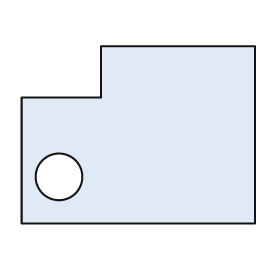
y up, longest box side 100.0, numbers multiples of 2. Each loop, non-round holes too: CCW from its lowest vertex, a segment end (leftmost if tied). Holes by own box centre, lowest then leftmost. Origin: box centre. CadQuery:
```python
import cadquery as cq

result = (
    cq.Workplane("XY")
    .moveTo(-50.0, -38.0)
    .lineTo(50.0, -38.0)
    .lineTo(50.0, 38.0)
    .lineTo(-16.0, 38.0)
    .lineTo(-16.0, 16.0)
    .lineTo(-50.0, 16.0)
    .close()
    .moveTo(-34.0, -18.0)
    .circle(10.0)
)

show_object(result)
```